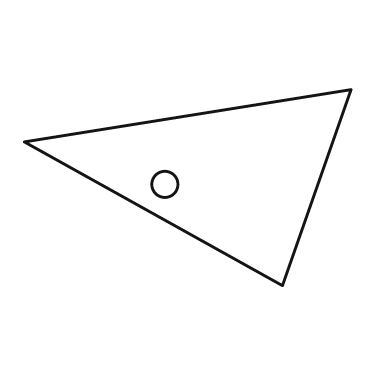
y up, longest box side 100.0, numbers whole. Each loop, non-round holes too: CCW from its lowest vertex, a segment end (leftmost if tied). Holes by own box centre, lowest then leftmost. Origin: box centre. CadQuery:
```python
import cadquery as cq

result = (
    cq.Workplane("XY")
    .moveTo(29.0, -30.0)
    .lineTo(50.0, 30.0)
    .lineTo(-50.0, 14.0)
    .close()
    .moveTo(-7.0, 1.0)
    .circle(4.0)
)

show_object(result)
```